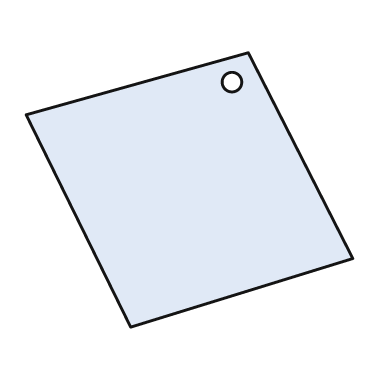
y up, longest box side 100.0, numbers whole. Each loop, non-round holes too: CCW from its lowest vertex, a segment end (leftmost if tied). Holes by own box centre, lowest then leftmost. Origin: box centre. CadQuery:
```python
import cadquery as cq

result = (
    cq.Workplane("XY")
    .moveTo(-18.0, -42.0)
    .lineTo(50.0, -21.0)
    .lineTo(18.0, 42.0)
    .lineTo(-50.0, 23.0)
    .close()
    .moveTo(13.0, 33.0)
    .circle(3.0)
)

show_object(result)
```